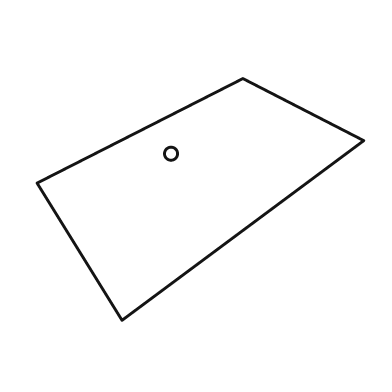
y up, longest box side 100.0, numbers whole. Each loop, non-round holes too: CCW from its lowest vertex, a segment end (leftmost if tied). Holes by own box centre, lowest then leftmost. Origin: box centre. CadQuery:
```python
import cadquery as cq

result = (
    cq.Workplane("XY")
    .moveTo(-24.0, -37.0)
    .lineTo(50.0, 18.0)
    .lineTo(13.0, 37.0)
    .lineTo(-50.0, 5.0)
    .close()
    .moveTo(-9.0, 14.0)
    .circle(2.0)
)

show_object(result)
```